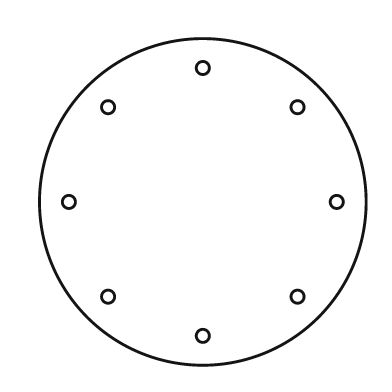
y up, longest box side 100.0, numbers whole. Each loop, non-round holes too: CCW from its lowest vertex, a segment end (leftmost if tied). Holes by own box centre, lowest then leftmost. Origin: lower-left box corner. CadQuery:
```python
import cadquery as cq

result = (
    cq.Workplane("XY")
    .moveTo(50.0, 50.0)
    .circle(50.0)
    .moveTo(50.0, 9.0)
    .circle(2.0)
    .moveTo(21.0, 21.0)
    .circle(2.0)
    .moveTo(79.0, 21.0)
    .circle(2.0)
    .moveTo(9.0, 50.0)
    .circle(2.0)
    .moveTo(91.0, 50.0)
    .circle(2.0)
    .moveTo(21.0, 79.0)
    .circle(2.0)
    .moveTo(79.0, 79.0)
    .circle(2.0)
    .moveTo(50.0, 91.0)
    .circle(2.0)
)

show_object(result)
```